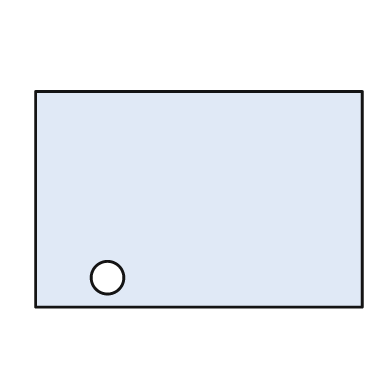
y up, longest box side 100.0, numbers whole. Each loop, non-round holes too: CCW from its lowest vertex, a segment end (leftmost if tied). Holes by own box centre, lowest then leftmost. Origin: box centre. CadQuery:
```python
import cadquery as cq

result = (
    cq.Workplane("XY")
    .moveTo(-50.0, -33.0)
    .lineTo(50.0, -33.0)
    .lineTo(50.0, 33.0)
    .lineTo(-50.0, 33.0)
    .close()
    .moveTo(-28.0, -24.0)
    .circle(5.0)
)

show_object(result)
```